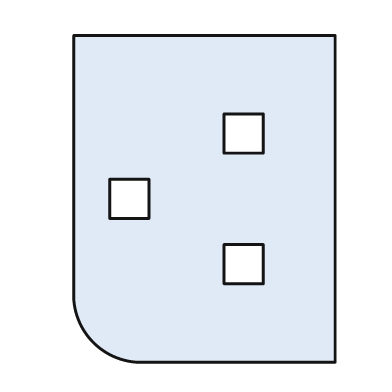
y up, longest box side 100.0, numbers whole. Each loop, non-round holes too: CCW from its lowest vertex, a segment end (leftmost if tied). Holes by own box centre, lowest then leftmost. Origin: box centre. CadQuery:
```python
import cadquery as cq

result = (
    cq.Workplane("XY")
    .moveTo(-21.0, -50.0)
    .lineTo(40.0, -50.0)
    .lineTo(40.0, 50.0)
    .lineTo(-40.0, 50.0)
    .lineTo(-40.0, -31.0)
    .threePointArc((-34.0, -44.0), (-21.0, -50.0))
    .close()
    .moveTo(6.0, -26.0)
    .lineTo(18.0, -26.0)
    .lineTo(18.0, -14.0)
    .lineTo(6.0, -14.0)
    .close()
    .moveTo(-29.0, -6.0)
    .lineTo(-17.0, -6.0)
    .lineTo(-17.0, 6.0)
    .lineTo(-29.0, 6.0)
    .close()
    .moveTo(6.0, 14.0)
    .lineTo(18.0, 14.0)
    .lineTo(18.0, 26.0)
    .lineTo(6.0, 26.0)
    .close()
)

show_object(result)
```